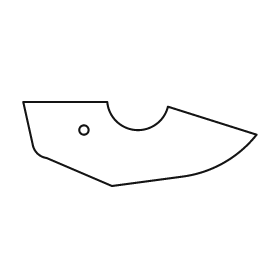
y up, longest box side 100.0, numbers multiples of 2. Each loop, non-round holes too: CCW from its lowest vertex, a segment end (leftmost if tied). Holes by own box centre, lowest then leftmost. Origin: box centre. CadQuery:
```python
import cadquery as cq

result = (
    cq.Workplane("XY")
    .moveTo(-12.0, -18.0)
    .lineTo(18.0, -14.0)
    .threePointArc((36.0, -8.0), (50.0, 4.0))
    .lineTo(12.0, 16.0)
    .threePointArc((-2.0, 6.0), (-14.0, 18.0))
    .lineTo(-50.0, 18.0)
    .lineTo(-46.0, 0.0)
    .threePointArc((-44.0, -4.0), (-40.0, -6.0))
    .close()
    .moveTo(-24.0, 6.0)
    .circle(2.0)
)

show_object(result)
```